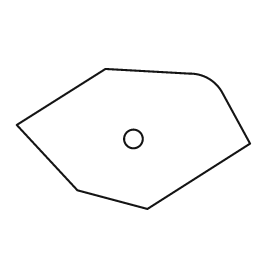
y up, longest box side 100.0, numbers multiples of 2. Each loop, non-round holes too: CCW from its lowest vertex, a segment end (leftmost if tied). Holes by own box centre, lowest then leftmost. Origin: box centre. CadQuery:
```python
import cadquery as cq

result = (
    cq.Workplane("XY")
    .moveTo(6.0, -30.0)
    .lineTo(50.0, -2.0)
    .lineTo(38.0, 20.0)
    .threePointArc((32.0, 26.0), (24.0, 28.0))
    .lineTo(-12.0, 30.0)
    .lineTo(-50.0, 6.0)
    .lineTo(-24.0, -22.0)
    .close()
    .moveTo(0.0, 0.0)
    .circle(4.0)
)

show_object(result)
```